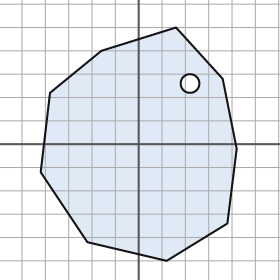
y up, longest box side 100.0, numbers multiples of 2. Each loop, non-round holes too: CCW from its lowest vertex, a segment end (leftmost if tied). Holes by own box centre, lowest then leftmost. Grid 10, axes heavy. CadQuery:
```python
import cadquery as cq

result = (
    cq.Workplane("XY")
    .moveTo(12.0, -50.0)
    .lineTo(38.0, -34.0)
    .lineTo(42.0, -2.0)
    .lineTo(36.0, 28.0)
    .lineTo(16.0, 50.0)
    .lineTo(-16.0, 40.0)
    .lineTo(-38.0, 22.0)
    .lineTo(-42.0, -12.0)
    .lineTo(-22.0, -42.0)
    .close()
    .moveTo(22.0, 26.0)
    .circle(4.0)
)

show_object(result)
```